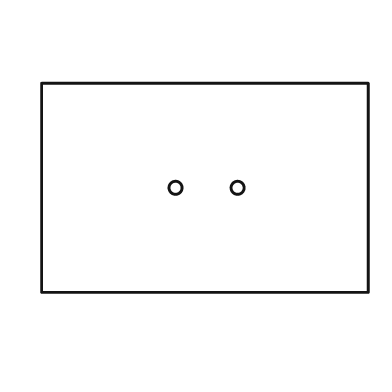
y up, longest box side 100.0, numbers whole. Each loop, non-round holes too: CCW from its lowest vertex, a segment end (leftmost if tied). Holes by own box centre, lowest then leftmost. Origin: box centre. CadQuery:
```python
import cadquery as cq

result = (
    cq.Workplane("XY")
    .moveTo(-50.0, -32.0)
    .lineTo(50.0, -32.0)
    .lineTo(50.0, 32.0)
    .lineTo(-50.0, 32.0)
    .close()
    .moveTo(-9.0, 0.0)
    .circle(2.0)
    .moveTo(10.0, 0.0)
    .circle(2.0)
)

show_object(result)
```